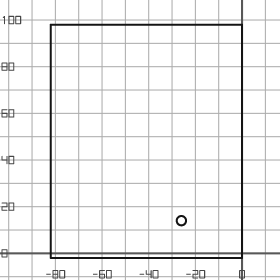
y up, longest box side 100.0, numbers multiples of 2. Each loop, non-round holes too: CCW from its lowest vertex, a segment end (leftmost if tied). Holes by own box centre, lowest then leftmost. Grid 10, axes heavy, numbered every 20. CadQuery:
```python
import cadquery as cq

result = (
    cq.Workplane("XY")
    .moveTo(-82.0, -2.0)
    .lineTo(0.0, -2.0)
    .lineTo(0.0, 98.0)
    .lineTo(-82.0, 98.0)
    .close()
    .moveTo(-26.0, 14.0)
    .circle(2.0)
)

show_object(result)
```